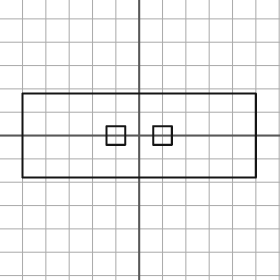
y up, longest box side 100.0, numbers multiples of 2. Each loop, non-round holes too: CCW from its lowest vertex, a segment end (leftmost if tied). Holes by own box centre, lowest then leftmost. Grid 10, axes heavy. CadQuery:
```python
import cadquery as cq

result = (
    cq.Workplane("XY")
    .moveTo(-50.0, -18.0)
    .lineTo(50.0, -18.0)
    .lineTo(50.0, 18.0)
    .lineTo(-50.0, 18.0)
    .close()
    .moveTo(-14.0, -4.0)
    .lineTo(-6.0, -4.0)
    .lineTo(-6.0, 4.0)
    .lineTo(-14.0, 4.0)
    .close()
    .moveTo(6.0, -4.0)
    .lineTo(14.0, -4.0)
    .lineTo(14.0, 4.0)
    .lineTo(6.0, 4.0)
    .close()
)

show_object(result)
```